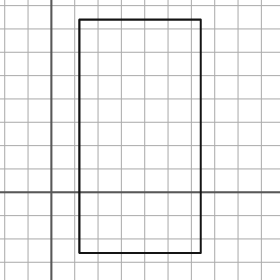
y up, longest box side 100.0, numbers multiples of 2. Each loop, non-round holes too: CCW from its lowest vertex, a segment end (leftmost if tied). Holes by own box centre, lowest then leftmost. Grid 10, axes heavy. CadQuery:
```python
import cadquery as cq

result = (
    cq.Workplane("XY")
    .moveTo(12.0, -26.0)
    .lineTo(64.0, -26.0)
    .lineTo(64.0, 74.0)
    .lineTo(12.0, 74.0)
    .close()
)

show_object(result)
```